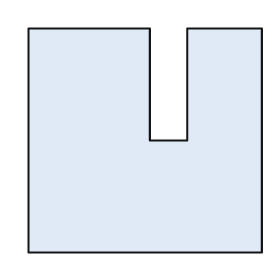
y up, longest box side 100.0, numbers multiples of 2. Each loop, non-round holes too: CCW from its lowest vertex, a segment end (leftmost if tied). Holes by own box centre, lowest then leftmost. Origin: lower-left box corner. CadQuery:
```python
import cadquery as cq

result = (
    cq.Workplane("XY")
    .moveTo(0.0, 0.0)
    .lineTo(100.0, 0.0)
    .lineTo(100.0, 96.0)
    .lineTo(68.0, 96.0)
    .lineTo(68.0, 48.0)
    .lineTo(52.0, 48.0)
    .lineTo(52.0, 96.0)
    .lineTo(0.0, 96.0)
    .close()
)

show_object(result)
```